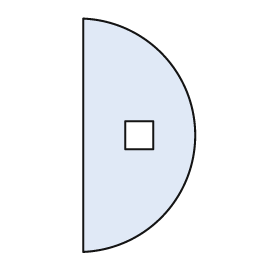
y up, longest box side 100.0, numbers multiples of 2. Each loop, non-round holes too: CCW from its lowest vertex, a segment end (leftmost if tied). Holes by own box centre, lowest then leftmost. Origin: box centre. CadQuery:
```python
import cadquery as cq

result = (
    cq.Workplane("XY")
    .moveTo(-24.0, -50.0)
    .threePointArc((24.0, 0.0), (-24.0, 50.0))
    .close()
    .moveTo(-6.0, -6.0)
    .lineTo(6.0, -6.0)
    .lineTo(6.0, 6.0)
    .lineTo(-6.0, 6.0)
    .close()
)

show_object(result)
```